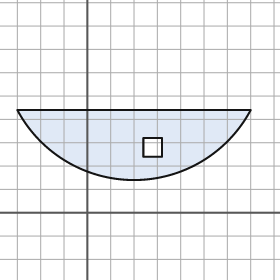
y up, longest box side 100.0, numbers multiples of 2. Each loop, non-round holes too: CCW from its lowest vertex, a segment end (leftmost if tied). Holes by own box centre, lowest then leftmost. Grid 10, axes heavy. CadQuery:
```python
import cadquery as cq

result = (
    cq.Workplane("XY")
    .moveTo(-30.0, 44.0)
    .threePointArc((20.0, 14.0), (70.0, 44.0))
    .close()
    .moveTo(24.0, 24.0)
    .lineTo(32.0, 24.0)
    .lineTo(32.0, 32.0)
    .lineTo(24.0, 32.0)
    .close()
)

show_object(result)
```